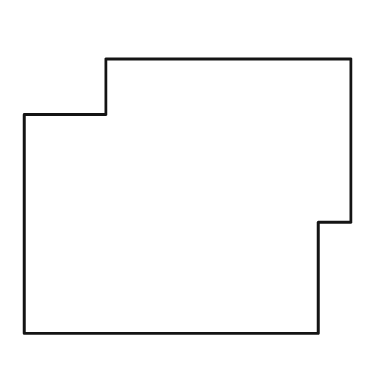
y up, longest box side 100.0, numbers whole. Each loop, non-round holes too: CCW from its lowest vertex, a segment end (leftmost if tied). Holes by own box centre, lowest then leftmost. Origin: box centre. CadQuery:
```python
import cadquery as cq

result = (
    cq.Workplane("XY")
    .moveTo(-50.0, -42.0)
    .lineTo(40.0, -42.0)
    .lineTo(40.0, -8.0)
    .lineTo(50.0, -8.0)
    .lineTo(50.0, 42.0)
    .lineTo(-25.0, 42.0)
    .lineTo(-25.0, 25.0)
    .lineTo(-50.0, 25.0)
    .close()
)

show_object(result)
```